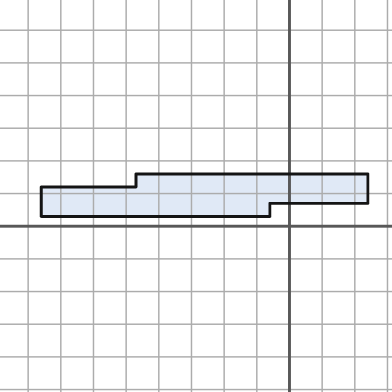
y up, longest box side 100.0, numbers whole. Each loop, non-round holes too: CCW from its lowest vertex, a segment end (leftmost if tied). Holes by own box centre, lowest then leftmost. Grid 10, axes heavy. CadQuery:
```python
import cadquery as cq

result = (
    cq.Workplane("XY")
    .moveTo(-76.0, 3.0)
    .lineTo(-6.0, 3.0)
    .lineTo(-6.0, 7.0)
    .lineTo(24.0, 7.0)
    .lineTo(24.0, 16.0)
    .lineTo(-47.0, 16.0)
    .lineTo(-47.0, 12.0)
    .lineTo(-76.0, 12.0)
    .close()
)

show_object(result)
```